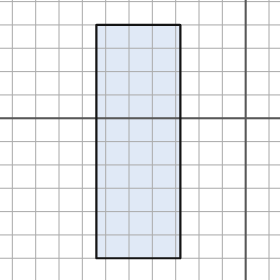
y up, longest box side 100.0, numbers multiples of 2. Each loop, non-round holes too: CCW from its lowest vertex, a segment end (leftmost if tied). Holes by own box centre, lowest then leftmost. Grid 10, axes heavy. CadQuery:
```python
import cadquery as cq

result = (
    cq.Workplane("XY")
    .moveTo(-64.0, -60.0)
    .lineTo(-28.0, -60.0)
    .lineTo(-28.0, 40.0)
    .lineTo(-64.0, 40.0)
    .close()
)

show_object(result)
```